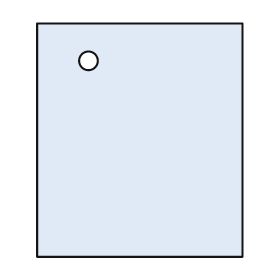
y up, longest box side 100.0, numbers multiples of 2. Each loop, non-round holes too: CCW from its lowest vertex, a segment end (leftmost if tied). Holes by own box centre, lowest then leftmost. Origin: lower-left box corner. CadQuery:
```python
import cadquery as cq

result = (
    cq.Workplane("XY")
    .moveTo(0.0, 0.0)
    .lineTo(88.0, 0.0)
    .lineTo(88.0, 100.0)
    .lineTo(0.0, 100.0)
    .close()
    .moveTo(22.0, 84.0)
    .circle(4.0)
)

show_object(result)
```